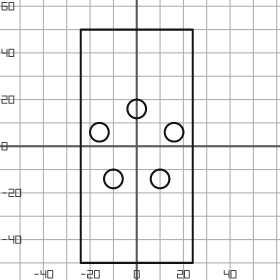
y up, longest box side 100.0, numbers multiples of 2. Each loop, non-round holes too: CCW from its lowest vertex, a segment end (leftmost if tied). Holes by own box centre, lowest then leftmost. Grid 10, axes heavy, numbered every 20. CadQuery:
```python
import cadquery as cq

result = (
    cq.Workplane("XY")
    .moveTo(-24.0, -50.0)
    .lineTo(24.0, -50.0)
    .lineTo(24.0, 50.0)
    .lineTo(-24.0, 50.0)
    .close()
    .moveTo(-10.0, -14.0)
    .circle(4.0)
    .moveTo(10.0, -14.0)
    .circle(4.0)
    .moveTo(-16.0, 6.0)
    .circle(4.0)
    .moveTo(16.0, 6.0)
    .circle(4.0)
    .moveTo(0.0, 16.0)
    .circle(4.0)
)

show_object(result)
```